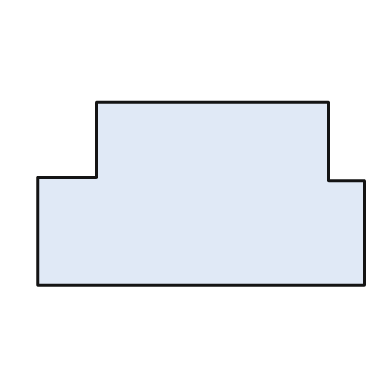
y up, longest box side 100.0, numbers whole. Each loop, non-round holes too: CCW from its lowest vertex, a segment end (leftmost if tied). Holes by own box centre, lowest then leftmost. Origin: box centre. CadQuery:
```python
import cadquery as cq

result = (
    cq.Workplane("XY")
    .moveTo(-50.0, -28.0)
    .lineTo(50.0, -28.0)
    .lineTo(50.0, 4.0)
    .lineTo(39.0, 4.0)
    .lineTo(39.0, 28.0)
    .lineTo(-32.0, 28.0)
    .lineTo(-32.0, 5.0)
    .lineTo(-50.0, 5.0)
    .close()
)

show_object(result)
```